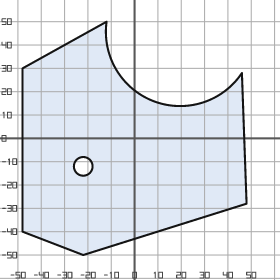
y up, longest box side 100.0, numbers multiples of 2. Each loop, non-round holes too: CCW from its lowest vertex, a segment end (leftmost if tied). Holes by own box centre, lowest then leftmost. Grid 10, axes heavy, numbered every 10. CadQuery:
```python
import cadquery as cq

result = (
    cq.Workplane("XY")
    .moveTo(-22.0, -50.0)
    .lineTo(48.0, -28.0)
    .lineTo(46.0, 28.0)
    .threePointArc((8.0, 16.0), (-12.0, 50.0))
    .lineTo(-48.0, 30.0)
    .lineTo(-48.0, -40.0)
    .close()
    .moveTo(-22.0, -12.0)
    .circle(4.0)
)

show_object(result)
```